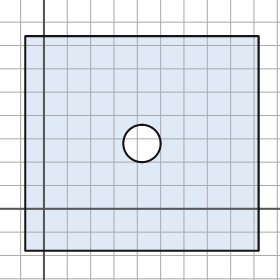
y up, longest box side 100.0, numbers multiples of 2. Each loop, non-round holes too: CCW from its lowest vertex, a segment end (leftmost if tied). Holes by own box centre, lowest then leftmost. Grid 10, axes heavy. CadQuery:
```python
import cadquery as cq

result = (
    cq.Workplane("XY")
    .moveTo(-8.0, -18.0)
    .lineTo(92.0, -18.0)
    .lineTo(92.0, 74.0)
    .lineTo(-8.0, 74.0)
    .close()
    .moveTo(42.0, 28.0)
    .circle(8.0)
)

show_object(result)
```